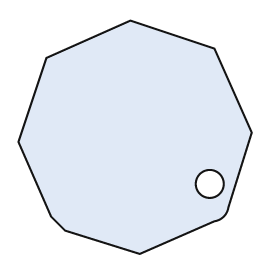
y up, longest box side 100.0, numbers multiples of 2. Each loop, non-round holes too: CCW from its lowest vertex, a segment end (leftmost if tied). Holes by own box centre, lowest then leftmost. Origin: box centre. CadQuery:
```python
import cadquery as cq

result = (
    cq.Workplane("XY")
    .moveTo(2.0, -50.0)
    .lineTo(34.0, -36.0)
    .threePointArc((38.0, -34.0), (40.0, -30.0))
    .lineTo(50.0, 2.0)
    .lineTo(34.0, 38.0)
    .lineTo(-2.0, 50.0)
    .lineTo(-38.0, 34.0)
    .lineTo(-50.0, -2.0)
    .lineTo(-36.0, -34.0)
    .lineTo(-30.0, -40.0)
    .close()
    .moveTo(32.0, -20.0)
    .circle(6.0)
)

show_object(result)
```